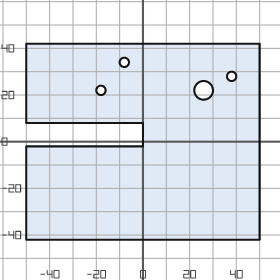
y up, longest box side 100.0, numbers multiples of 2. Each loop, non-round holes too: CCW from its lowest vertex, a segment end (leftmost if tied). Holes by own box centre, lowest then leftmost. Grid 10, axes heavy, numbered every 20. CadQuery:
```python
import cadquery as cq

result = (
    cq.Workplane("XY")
    .moveTo(-50.0, -42.0)
    .lineTo(50.0, -42.0)
    .lineTo(50.0, 42.0)
    .lineTo(-50.0, 42.0)
    .lineTo(-50.0, 8.0)
    .lineTo(0.0, 8.0)
    .lineTo(0.0, -2.0)
    .lineTo(-50.0, -2.0)
    .close()
    .moveTo(-18.0, 22.0)
    .circle(2.0)
    .moveTo(26.0, 22.0)
    .circle(4.0)
    .moveTo(38.0, 28.0)
    .circle(2.0)
    .moveTo(-8.0, 34.0)
    .circle(2.0)
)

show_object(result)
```